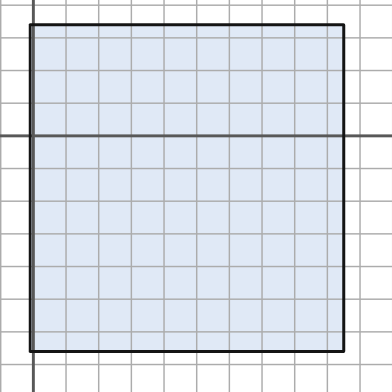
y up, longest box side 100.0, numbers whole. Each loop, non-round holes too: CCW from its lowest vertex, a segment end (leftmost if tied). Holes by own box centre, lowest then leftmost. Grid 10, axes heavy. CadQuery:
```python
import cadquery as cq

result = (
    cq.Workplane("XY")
    .moveTo(-1.0, -66.0)
    .lineTo(95.0, -66.0)
    .lineTo(95.0, 34.0)
    .lineTo(-1.0, 34.0)
    .close()
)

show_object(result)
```